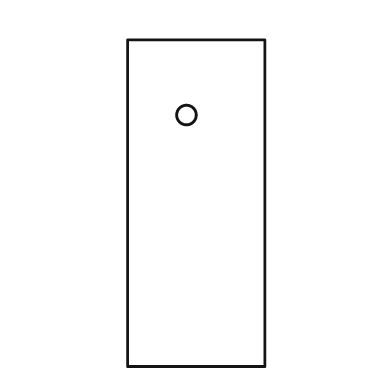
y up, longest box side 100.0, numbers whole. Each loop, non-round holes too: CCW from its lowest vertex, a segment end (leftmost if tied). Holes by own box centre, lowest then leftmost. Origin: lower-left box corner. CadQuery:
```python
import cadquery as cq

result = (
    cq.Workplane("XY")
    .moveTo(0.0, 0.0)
    .lineTo(42.0, 0.0)
    .lineTo(42.0, 100.0)
    .lineTo(0.0, 100.0)
    .close()
    .moveTo(18.0, 77.0)
    .circle(3.0)
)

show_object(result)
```